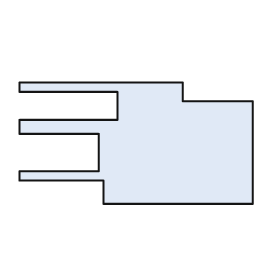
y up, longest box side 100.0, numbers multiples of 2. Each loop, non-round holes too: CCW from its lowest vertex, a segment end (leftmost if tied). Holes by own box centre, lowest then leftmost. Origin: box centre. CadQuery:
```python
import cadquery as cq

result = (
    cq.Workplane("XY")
    .moveTo(-14.0, -26.0)
    .lineTo(50.0, -26.0)
    .lineTo(50.0, 18.0)
    .lineTo(20.0, 18.0)
    .lineTo(20.0, 26.0)
    .lineTo(-50.0, 26.0)
    .lineTo(-50.0, 22.0)
    .lineTo(-8.0, 22.0)
    .lineTo(-8.0, 10.0)
    .lineTo(-50.0, 10.0)
    .lineTo(-50.0, 4.0)
    .lineTo(-16.0, 4.0)
    .lineTo(-16.0, -12.0)
    .lineTo(-50.0, -12.0)
    .lineTo(-50.0, -16.0)
    .lineTo(-14.0, -16.0)
    .close()
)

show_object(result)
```